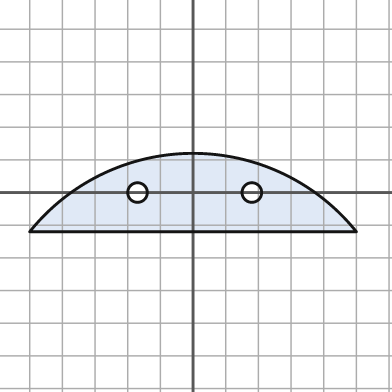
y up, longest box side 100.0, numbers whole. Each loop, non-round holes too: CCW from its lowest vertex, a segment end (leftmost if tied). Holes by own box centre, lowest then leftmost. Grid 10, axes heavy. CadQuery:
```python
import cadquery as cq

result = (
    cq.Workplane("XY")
    .moveTo(-50.0, -12.0)
    .lineTo(50.0, -12.0)
    .threePointArc((0.0, 12.0), (-50.0, -12.0))
    .close()
    .moveTo(-17.0, 0.0)
    .circle(3.0)
    .moveTo(18.0, 0.0)
    .circle(3.0)
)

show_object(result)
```